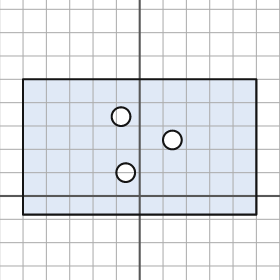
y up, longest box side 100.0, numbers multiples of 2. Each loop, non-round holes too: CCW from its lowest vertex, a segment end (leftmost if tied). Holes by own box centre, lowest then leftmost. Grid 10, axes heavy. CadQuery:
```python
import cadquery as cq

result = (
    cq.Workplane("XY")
    .moveTo(-50.0, -8.0)
    .lineTo(50.0, -8.0)
    .lineTo(50.0, 50.0)
    .lineTo(-50.0, 50.0)
    .close()
    .moveTo(-6.0, 10.0)
    .circle(4.0)
    .moveTo(14.0, 24.0)
    .circle(4.0)
    .moveTo(-8.0, 34.0)
    .circle(4.0)
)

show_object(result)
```